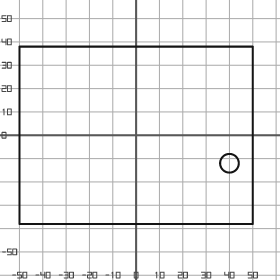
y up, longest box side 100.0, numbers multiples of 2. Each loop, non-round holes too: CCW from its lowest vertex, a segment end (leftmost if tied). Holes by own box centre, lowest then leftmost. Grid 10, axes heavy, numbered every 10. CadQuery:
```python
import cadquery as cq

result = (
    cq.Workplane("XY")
    .moveTo(-50.0, -38.0)
    .lineTo(50.0, -38.0)
    .lineTo(50.0, 38.0)
    .lineTo(-50.0, 38.0)
    .close()
    .moveTo(40.0, -12.0)
    .circle(4.0)
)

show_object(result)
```